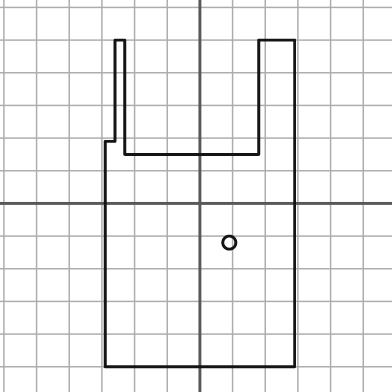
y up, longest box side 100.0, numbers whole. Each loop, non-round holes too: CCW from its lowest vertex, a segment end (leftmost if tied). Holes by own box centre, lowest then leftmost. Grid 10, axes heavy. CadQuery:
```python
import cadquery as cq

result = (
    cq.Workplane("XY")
    .moveTo(-29.0, -50.0)
    .lineTo(29.0, -50.0)
    .lineTo(29.0, 50.0)
    .lineTo(18.0, 50.0)
    .lineTo(18.0, 15.0)
    .lineTo(-23.0, 15.0)
    .lineTo(-23.0, 50.0)
    .lineTo(-26.0, 50.0)
    .lineTo(-26.0, 19.0)
    .lineTo(-29.0, 19.0)
    .close()
    .moveTo(9.0, -12.0)
    .circle(2.0)
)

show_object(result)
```